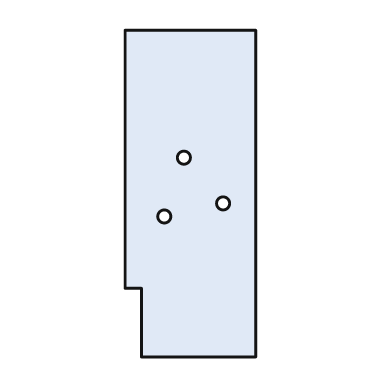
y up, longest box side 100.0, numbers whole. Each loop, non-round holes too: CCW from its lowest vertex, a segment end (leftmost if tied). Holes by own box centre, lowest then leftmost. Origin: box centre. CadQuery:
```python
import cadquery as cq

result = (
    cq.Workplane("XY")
    .moveTo(-15.0, -50.0)
    .lineTo(20.0, -50.0)
    .lineTo(20.0, 50.0)
    .lineTo(-20.0, 50.0)
    .lineTo(-20.0, -29.0)
    .lineTo(-15.0, -29.0)
    .close()
    .moveTo(-8.0, -7.0)
    .circle(2.0)
    .moveTo(10.0, -3.0)
    .circle(2.0)
    .moveTo(-2.0, 11.0)
    .circle(2.0)
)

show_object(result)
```